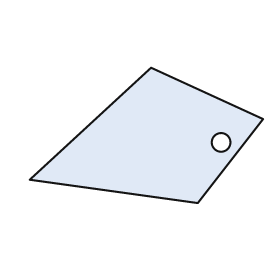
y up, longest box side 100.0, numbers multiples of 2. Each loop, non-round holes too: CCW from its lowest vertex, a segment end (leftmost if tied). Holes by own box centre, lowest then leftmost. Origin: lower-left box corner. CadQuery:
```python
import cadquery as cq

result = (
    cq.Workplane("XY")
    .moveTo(72.0, 0.0)
    .lineTo(100.0, 36.0)
    .lineTo(52.0, 58.0)
    .lineTo(0.0, 10.0)
    .close()
    .moveTo(82.0, 26.0)
    .circle(4.0)
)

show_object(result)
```